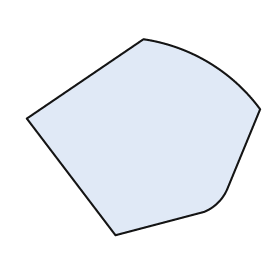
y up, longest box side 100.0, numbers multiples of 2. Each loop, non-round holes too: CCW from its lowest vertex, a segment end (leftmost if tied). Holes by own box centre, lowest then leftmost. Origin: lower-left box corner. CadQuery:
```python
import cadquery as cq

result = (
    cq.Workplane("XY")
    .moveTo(38.0, 0.0)
    .lineTo(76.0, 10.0)
    .threePointArc((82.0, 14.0), (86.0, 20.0))
    .lineTo(100.0, 54.0)
    .threePointArc((78.0, 74.0), (50.0, 84.0))
    .lineTo(0.0, 50.0)
    .close()
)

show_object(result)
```